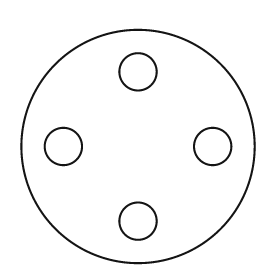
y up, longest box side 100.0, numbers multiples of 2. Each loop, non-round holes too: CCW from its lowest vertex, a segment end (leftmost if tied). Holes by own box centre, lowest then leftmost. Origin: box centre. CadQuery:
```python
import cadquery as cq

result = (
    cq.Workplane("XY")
    .moveTo(0.0, 0.0)
    .circle(50.0)
    .moveTo(0.0, -32.0)
    .circle(8.0)
    .moveTo(-32.0, 0.0)
    .circle(8.0)
    .moveTo(32.0, 0.0)
    .circle(8.0)
    .moveTo(0.0, 32.0)
    .circle(8.0)
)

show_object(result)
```